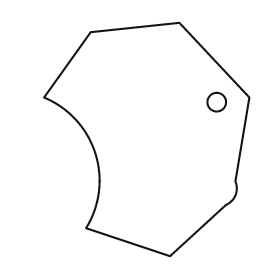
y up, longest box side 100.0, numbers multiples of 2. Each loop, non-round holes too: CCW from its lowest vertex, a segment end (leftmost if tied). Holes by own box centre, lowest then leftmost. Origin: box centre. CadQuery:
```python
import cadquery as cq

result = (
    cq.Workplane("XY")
    .moveTo(10.0, -50.0)
    .lineTo(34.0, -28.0)
    .threePointArc((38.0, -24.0), (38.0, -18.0))
    .lineTo(44.0, 18.0)
    .lineTo(14.0, 50.0)
    .lineTo(-24.0, 46.0)
    .lineTo(-44.0, 18.0)
    .threePointArc((-22.0, -6.0), (-26.0, -38.0))
    .close()
    .moveTo(30.0, 16.0)
    .circle(4.0)
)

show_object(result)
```